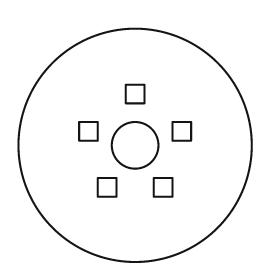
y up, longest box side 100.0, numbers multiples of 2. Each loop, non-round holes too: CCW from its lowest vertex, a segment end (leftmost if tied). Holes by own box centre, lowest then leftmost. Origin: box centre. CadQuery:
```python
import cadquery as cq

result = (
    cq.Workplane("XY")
    .moveTo(0.0, 0.0)
    .circle(50.0)
    .moveTo(-16.0, -22.0)
    .lineTo(-8.0, -22.0)
    .lineTo(-8.0, -14.0)
    .lineTo(-16.0, -14.0)
    .close()
    .moveTo(8.0, -22.0)
    .lineTo(16.0, -22.0)
    .lineTo(16.0, -14.0)
    .lineTo(8.0, -14.0)
    .close()
    .moveTo(0.0, 0.0)
    .circle(10.0)
    .moveTo(-24.0, 2.0)
    .lineTo(-16.0, 2.0)
    .lineTo(-16.0, 10.0)
    .lineTo(-24.0, 10.0)
    .close()
    .moveTo(16.0, 2.0)
    .lineTo(24.0, 2.0)
    .lineTo(24.0, 10.0)
    .lineTo(16.0, 10.0)
    .close()
    .moveTo(-4.0, 18.0)
    .lineTo(4.0, 18.0)
    .lineTo(4.0, 26.0)
    .lineTo(-4.0, 26.0)
    .close()
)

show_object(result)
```